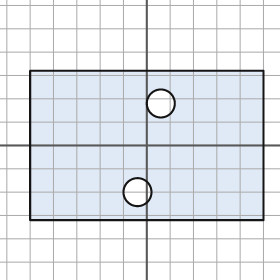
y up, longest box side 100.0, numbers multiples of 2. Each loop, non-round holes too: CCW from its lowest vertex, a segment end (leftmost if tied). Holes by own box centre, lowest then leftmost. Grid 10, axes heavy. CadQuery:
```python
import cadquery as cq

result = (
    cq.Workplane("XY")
    .moveTo(-50.0, -32.0)
    .lineTo(50.0, -32.0)
    .lineTo(50.0, 32.0)
    .lineTo(-50.0, 32.0)
    .close()
    .moveTo(-4.0, -20.0)
    .circle(6.0)
    .moveTo(6.0, 18.0)
    .circle(6.0)
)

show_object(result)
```